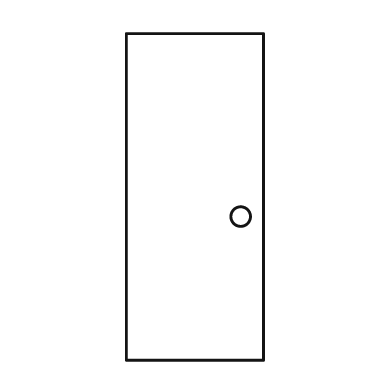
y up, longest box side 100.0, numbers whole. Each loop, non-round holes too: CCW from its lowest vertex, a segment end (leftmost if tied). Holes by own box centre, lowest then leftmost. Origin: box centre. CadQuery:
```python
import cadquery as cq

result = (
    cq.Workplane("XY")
    .moveTo(-21.0, -50.0)
    .lineTo(21.0, -50.0)
    .lineTo(21.0, 50.0)
    .lineTo(-21.0, 50.0)
    .close()
    .moveTo(14.0, -6.0)
    .circle(3.0)
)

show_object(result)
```